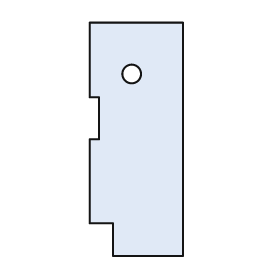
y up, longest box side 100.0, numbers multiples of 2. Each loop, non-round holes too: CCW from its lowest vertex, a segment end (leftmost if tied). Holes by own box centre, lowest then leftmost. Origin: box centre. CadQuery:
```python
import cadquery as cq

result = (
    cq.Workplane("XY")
    .moveTo(-10.0, -50.0)
    .lineTo(20.0, -50.0)
    .lineTo(20.0, 50.0)
    .lineTo(-20.0, 50.0)
    .lineTo(-20.0, 18.0)
    .lineTo(-16.0, 18.0)
    .lineTo(-16.0, 0.0)
    .lineTo(-20.0, 0.0)
    .lineTo(-20.0, -36.0)
    .lineTo(-10.0, -36.0)
    .close()
    .moveTo(-2.0, 28.0)
    .circle(4.0)
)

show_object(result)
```